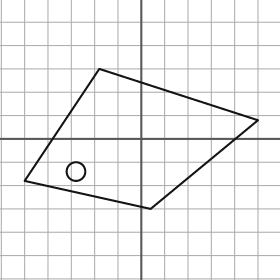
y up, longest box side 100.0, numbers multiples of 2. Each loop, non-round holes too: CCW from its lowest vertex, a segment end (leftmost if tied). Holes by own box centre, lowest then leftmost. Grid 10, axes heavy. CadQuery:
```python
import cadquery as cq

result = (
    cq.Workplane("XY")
    .moveTo(4.0, -30.0)
    .lineTo(50.0, 8.0)
    .lineTo(-18.0, 30.0)
    .lineTo(-50.0, -18.0)
    .close()
    .moveTo(-28.0, -14.0)
    .circle(4.0)
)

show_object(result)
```